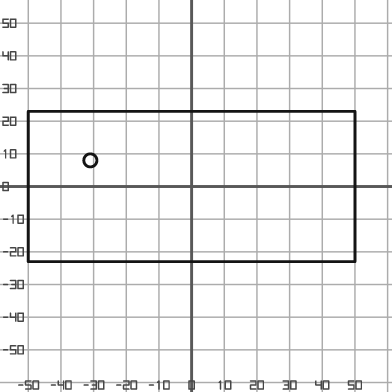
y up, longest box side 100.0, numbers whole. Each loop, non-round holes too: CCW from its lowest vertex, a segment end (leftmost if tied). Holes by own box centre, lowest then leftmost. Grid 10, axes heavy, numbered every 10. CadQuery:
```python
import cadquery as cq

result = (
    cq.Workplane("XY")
    .moveTo(-50.0, -23.0)
    .lineTo(50.0, -23.0)
    .lineTo(50.0, 23.0)
    .lineTo(-50.0, 23.0)
    .close()
    .moveTo(-31.0, 8.0)
    .circle(2.0)
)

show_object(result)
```